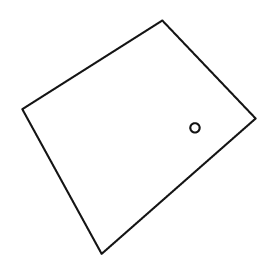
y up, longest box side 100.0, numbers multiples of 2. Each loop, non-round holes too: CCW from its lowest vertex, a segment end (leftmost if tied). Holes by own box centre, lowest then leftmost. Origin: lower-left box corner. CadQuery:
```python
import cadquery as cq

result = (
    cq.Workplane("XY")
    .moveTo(34.0, 0.0)
    .lineTo(100.0, 58.0)
    .lineTo(60.0, 100.0)
    .lineTo(0.0, 62.0)
    .close()
    .moveTo(74.0, 54.0)
    .circle(2.0)
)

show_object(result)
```